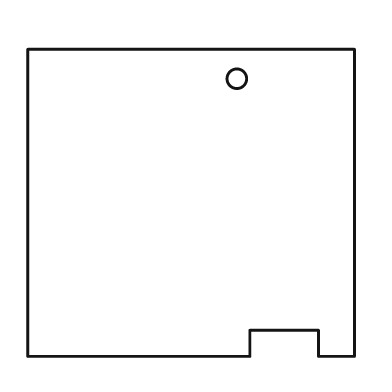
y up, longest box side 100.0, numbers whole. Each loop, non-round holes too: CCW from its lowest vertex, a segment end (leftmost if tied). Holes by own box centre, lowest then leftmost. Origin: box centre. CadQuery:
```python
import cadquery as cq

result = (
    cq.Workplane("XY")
    .moveTo(-50.0, -47.0)
    .lineTo(18.0, -47.0)
    .lineTo(18.0, -39.0)
    .lineTo(39.0, -39.0)
    .lineTo(39.0, -47.0)
    .lineTo(50.0, -47.0)
    .lineTo(50.0, 47.0)
    .lineTo(-50.0, 47.0)
    .close()
    .moveTo(14.0, 38.0)
    .circle(3.0)
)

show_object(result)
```